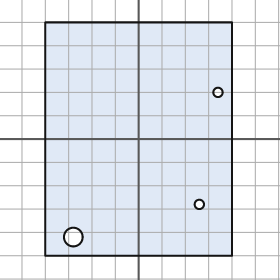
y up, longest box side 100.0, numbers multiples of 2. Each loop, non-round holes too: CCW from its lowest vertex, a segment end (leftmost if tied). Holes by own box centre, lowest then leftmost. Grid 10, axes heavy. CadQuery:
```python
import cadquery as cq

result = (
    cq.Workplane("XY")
    .moveTo(-40.0, -50.0)
    .lineTo(40.0, -50.0)
    .lineTo(40.0, 50.0)
    .lineTo(-40.0, 50.0)
    .close()
    .moveTo(-28.0, -42.0)
    .circle(4.0)
    .moveTo(26.0, -28.0)
    .circle(2.0)
    .moveTo(34.0, 20.0)
    .circle(2.0)
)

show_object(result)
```